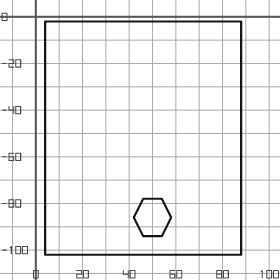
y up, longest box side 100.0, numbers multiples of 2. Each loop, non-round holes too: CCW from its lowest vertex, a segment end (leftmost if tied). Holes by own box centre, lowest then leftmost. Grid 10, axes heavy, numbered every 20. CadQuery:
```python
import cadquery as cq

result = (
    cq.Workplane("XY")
    .moveTo(4.0, -102.0)
    .lineTo(88.0, -102.0)
    .lineTo(88.0, -2.0)
    .lineTo(4.0, -2.0)
    .close()
    .moveTo(46.0, -94.0)
    .lineTo(54.0, -94.0)
    .lineTo(58.0, -86.0)
    .lineTo(54.0, -78.0)
    .lineTo(46.0, -78.0)
    .lineTo(42.0, -86.0)
    .close()
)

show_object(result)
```